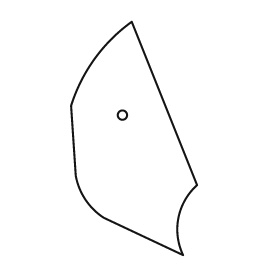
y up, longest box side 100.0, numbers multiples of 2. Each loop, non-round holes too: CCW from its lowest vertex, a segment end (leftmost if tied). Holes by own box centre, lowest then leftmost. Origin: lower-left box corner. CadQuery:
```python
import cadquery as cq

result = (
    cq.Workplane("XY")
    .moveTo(48.0, 0.0)
    .threePointArc((46.0, 16.0), (54.0, 30.0))
    .lineTo(26.0, 100.0)
    .threePointArc((10.0, 84.0), (0.0, 64.0))
    .lineTo(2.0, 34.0)
    .threePointArc((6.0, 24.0), (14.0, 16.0))
    .close()
    .moveTo(22.0, 60.0)
    .circle(2.0)
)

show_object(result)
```